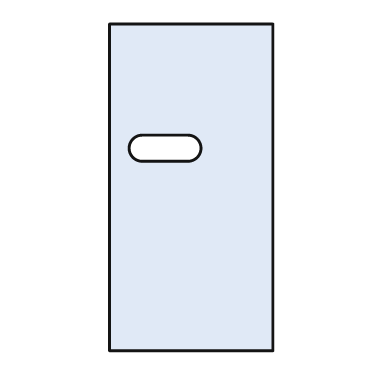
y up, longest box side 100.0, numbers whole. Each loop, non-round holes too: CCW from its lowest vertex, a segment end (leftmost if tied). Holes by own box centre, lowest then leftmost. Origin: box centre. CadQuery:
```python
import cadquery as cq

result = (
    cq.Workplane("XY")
    .moveTo(-25.0, -50.0)
    .lineTo(25.0, -50.0)
    .lineTo(25.0, 50.0)
    .lineTo(-25.0, 50.0)
    .close()
    .moveTo(-15.0, 8.0)
    .lineTo(-1.0, 8.0)
    .threePointArc((3.0, 12.0), (-1.0, 16.0))
    .lineTo(-15.0, 16.0)
    .threePointArc((-19.0, 12.0), (-15.0, 8.0))
    .close()
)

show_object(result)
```